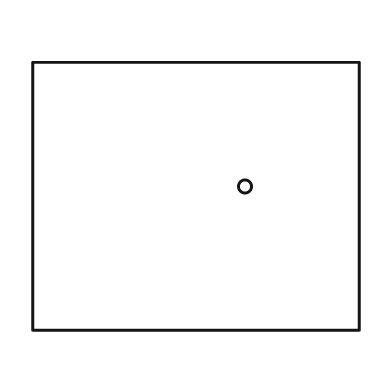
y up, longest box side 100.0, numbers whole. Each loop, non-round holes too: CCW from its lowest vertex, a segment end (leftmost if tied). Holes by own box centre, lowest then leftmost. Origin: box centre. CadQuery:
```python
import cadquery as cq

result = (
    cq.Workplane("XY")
    .moveTo(-50.0, -41.0)
    .lineTo(50.0, -41.0)
    .lineTo(50.0, 41.0)
    .lineTo(-50.0, 41.0)
    .close()
    .moveTo(15.0, 3.0)
    .circle(2.0)
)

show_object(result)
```